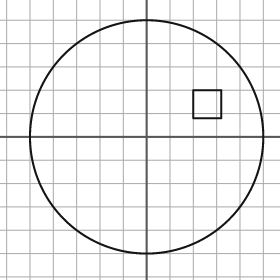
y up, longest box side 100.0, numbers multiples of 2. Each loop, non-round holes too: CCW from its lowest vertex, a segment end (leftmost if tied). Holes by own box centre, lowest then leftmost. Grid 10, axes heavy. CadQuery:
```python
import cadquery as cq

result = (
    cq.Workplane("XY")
    .moveTo(0.0, 0.0)
    .circle(50.0)
    .moveTo(20.0, 8.0)
    .lineTo(32.0, 8.0)
    .lineTo(32.0, 20.0)
    .lineTo(20.0, 20.0)
    .close()
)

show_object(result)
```